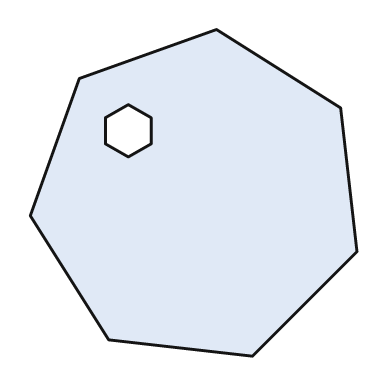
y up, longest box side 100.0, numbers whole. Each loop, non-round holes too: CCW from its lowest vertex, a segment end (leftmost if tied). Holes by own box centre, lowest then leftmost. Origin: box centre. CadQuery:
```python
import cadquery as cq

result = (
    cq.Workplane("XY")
    .moveTo(18.0, -50.0)
    .lineTo(50.0, -18.0)
    .lineTo(45.0, 26.0)
    .lineTo(7.0, 50.0)
    .lineTo(-35.0, 35.0)
    .lineTo(-50.0, -7.0)
    .lineTo(-26.0, -45.0)
    .close()
    .moveTo(-20.0, 11.0)
    .lineTo(-13.0, 15.0)
    .lineTo(-13.0, 23.0)
    .lineTo(-20.0, 27.0)
    .lineTo(-27.0, 23.0)
    .lineTo(-27.0, 15.0)
    .close()
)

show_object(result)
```